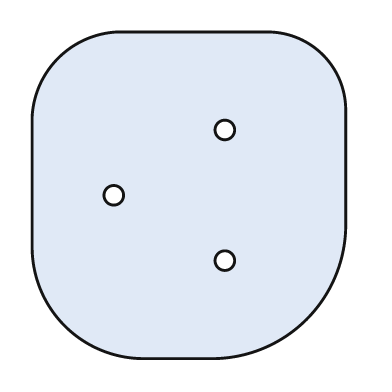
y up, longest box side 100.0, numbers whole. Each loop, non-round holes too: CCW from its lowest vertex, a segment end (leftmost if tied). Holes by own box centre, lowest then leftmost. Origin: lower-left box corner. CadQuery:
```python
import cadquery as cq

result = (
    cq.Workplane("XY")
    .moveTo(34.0, 0.0)
    .lineTo(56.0, 0.0)
    .threePointArc((84.0, 12.0), (96.0, 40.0))
    .lineTo(96.0, 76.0)
    .threePointArc((89.0, 93.0), (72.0, 100.0))
    .lineTo(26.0, 100.0)
    .threePointArc((8.0, 92.0), (0.0, 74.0))
    .lineTo(0.0, 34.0)
    .threePointArc((10.0, 10.0), (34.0, 0.0))
    .close()
    .moveTo(59.0, 30.0)
    .circle(3.0)
    .moveTo(25.0, 50.0)
    .circle(3.0)
    .moveTo(59.0, 70.0)
    .circle(3.0)
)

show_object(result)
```